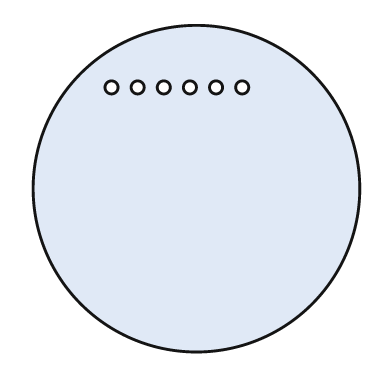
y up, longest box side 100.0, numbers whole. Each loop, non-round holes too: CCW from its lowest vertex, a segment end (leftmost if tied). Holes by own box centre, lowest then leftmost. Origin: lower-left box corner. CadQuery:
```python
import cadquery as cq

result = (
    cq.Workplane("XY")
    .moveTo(50.0, 50.0)
    .circle(50.0)
    .moveTo(24.0, 81.0)
    .circle(2.0)
    .moveTo(32.0, 81.0)
    .circle(2.0)
    .moveTo(40.0, 81.0)
    .circle(2.0)
    .moveTo(48.0, 81.0)
    .circle(2.0)
    .moveTo(56.0, 81.0)
    .circle(2.0)
    .moveTo(64.0, 81.0)
    .circle(2.0)
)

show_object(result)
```